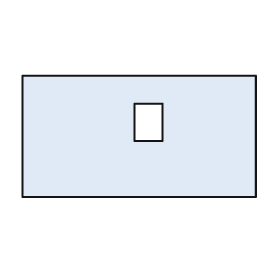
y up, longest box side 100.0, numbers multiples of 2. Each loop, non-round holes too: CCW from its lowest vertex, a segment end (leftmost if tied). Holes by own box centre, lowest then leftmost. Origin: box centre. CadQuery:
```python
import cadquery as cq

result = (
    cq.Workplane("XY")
    .moveTo(-50.0, -26.0)
    .lineTo(50.0, -26.0)
    .lineTo(50.0, 26.0)
    .lineTo(-50.0, 26.0)
    .close()
    .moveTo(-2.0, -2.0)
    .lineTo(10.0, -2.0)
    .lineTo(10.0, 14.0)
    .lineTo(-2.0, 14.0)
    .close()
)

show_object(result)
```